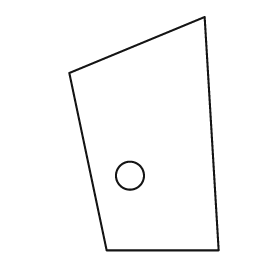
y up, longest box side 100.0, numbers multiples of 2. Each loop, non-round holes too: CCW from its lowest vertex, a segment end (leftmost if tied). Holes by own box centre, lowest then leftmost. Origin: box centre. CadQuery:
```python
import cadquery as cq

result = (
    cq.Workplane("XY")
    .moveTo(-16.0, -50.0)
    .lineTo(32.0, -50.0)
    .lineTo(26.0, 50.0)
    .lineTo(-32.0, 26.0)
    .close()
    .moveTo(-6.0, -18.0)
    .circle(6.0)
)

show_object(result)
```